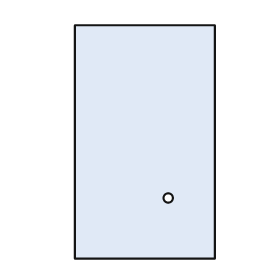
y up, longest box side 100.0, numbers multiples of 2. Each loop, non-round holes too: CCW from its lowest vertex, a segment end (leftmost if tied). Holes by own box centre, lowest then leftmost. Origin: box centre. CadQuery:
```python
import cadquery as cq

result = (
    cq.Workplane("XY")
    .moveTo(-30.0, -50.0)
    .lineTo(30.0, -50.0)
    .lineTo(30.0, 50.0)
    .lineTo(-30.0, 50.0)
    .close()
    .moveTo(10.0, -24.0)
    .circle(2.0)
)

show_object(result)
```